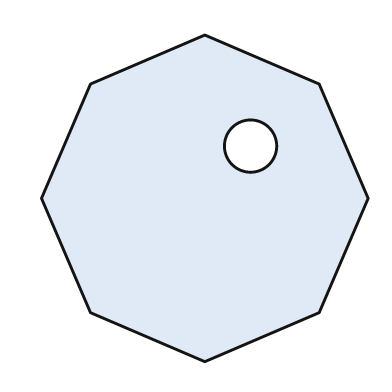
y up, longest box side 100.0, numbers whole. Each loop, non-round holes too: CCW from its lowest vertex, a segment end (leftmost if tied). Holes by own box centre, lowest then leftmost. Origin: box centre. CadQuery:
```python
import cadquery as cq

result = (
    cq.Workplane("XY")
    .moveTo(0.0, -50.0)
    .lineTo(35.0, -35.0)
    .lineTo(50.0, 0.0)
    .lineTo(35.0, 35.0)
    .lineTo(0.0, 50.0)
    .lineTo(-35.0, 35.0)
    .lineTo(-50.0, 0.0)
    .lineTo(-35.0, -35.0)
    .close()
    .moveTo(14.0, 16.0)
    .circle(8.0)
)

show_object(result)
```